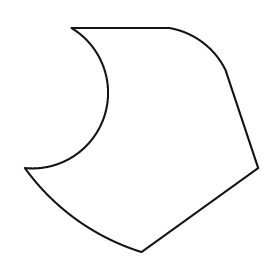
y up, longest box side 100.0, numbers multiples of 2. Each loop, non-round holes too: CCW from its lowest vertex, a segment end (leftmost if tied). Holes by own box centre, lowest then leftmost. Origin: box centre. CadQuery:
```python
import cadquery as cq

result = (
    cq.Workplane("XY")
    .moveTo(0.0, -48.0)
    .lineTo(50.0, -12.0)
    .lineTo(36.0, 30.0)
    .threePointArc((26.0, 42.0), (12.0, 48.0))
    .lineTo(-30.0, 48.0)
    .threePointArc((-16.0, 10.0), (-50.0, -12.0))
    .threePointArc((-28.0, -34.0), (0.0, -48.0))
    .close()
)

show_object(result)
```